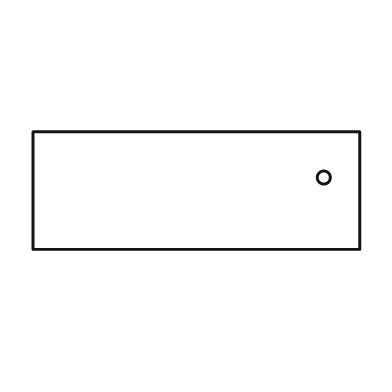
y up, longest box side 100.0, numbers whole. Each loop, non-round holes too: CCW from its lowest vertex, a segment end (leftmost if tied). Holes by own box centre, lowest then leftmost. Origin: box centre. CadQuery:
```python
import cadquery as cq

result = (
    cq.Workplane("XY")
    .moveTo(-50.0, -18.0)
    .lineTo(50.0, -18.0)
    .lineTo(50.0, 18.0)
    .lineTo(-50.0, 18.0)
    .close()
    .moveTo(39.0, 4.0)
    .circle(2.0)
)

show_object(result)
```